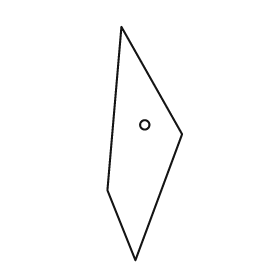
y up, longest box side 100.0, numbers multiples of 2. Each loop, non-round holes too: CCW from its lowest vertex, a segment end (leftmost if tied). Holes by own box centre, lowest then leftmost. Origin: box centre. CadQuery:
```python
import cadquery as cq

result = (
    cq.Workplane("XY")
    .moveTo(-4.0, -50.0)
    .lineTo(16.0, 4.0)
    .lineTo(-10.0, 50.0)
    .lineTo(-16.0, -20.0)
    .close()
    .moveTo(0.0, 8.0)
    .circle(2.0)
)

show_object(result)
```